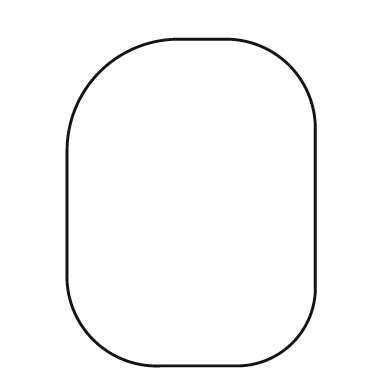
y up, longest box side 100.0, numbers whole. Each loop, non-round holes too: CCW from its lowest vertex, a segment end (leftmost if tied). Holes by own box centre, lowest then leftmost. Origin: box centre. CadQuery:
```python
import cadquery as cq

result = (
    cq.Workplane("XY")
    .moveTo(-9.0, -50.0)
    .lineTo(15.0, -50.0)
    .threePointArc((31.0, -43.0), (38.0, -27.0))
    .lineTo(38.0, 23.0)
    .threePointArc((30.0, 42.0), (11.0, 50.0))
    .lineTo(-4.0, 50.0)
    .threePointArc((-28.0, 40.0), (-38.0, 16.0))
    .lineTo(-38.0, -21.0)
    .threePointArc((-30.0, -42.0), (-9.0, -50.0))
    .close()
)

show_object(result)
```